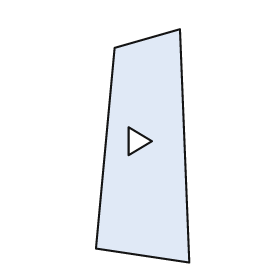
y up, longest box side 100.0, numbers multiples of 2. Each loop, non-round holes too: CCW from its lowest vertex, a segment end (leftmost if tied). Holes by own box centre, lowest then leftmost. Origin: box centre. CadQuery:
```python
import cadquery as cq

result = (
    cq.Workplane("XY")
    .moveTo(20.0, -50.0)
    .lineTo(16.0, 50.0)
    .lineTo(-12.0, 42.0)
    .lineTo(-20.0, -44.0)
    .close()
    .moveTo(-6.0, -4.0)
    .lineTo(4.0, 2.0)
    .lineTo(-6.0, 8.0)
    .close()
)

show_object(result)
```